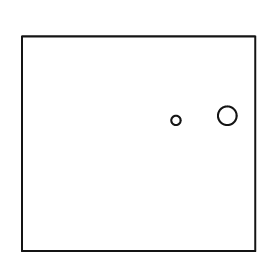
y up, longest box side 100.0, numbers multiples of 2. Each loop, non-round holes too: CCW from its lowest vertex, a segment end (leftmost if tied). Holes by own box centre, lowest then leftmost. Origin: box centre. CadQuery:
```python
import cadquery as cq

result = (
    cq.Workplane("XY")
    .moveTo(-50.0, -46.0)
    .lineTo(50.0, -46.0)
    .lineTo(50.0, 46.0)
    .lineTo(-50.0, 46.0)
    .close()
    .moveTo(16.0, 10.0)
    .circle(2.0)
    .moveTo(38.0, 12.0)
    .circle(4.0)
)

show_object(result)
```